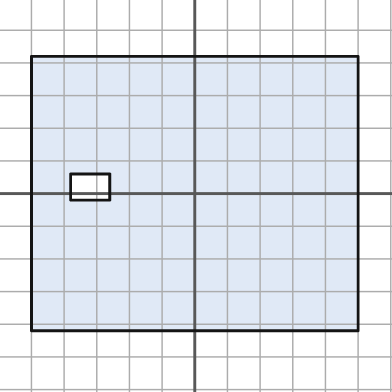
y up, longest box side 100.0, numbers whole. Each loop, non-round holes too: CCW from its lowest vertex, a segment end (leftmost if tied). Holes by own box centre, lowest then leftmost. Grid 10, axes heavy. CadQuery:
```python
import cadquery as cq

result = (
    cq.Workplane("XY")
    .moveTo(-50.0, -42.0)
    .lineTo(50.0, -42.0)
    .lineTo(50.0, 42.0)
    .lineTo(-50.0, 42.0)
    .close()
    .moveTo(-38.0, -2.0)
    .lineTo(-26.0, -2.0)
    .lineTo(-26.0, 6.0)
    .lineTo(-38.0, 6.0)
    .close()
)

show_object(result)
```